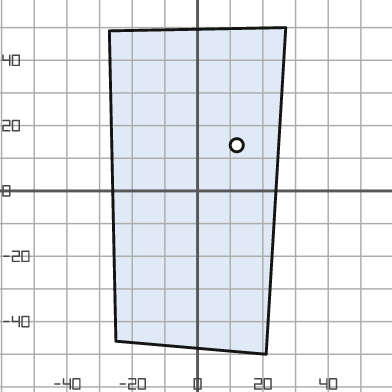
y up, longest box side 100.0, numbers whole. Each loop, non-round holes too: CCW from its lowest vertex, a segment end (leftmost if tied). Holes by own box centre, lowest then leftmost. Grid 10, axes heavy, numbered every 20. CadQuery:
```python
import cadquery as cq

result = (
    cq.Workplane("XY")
    .moveTo(21.0, -50.0)
    .lineTo(27.0, 50.0)
    .lineTo(-27.0, 49.0)
    .lineTo(-25.0, -46.0)
    .close()
    .moveTo(12.0, 14.0)
    .circle(2.0)
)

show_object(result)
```